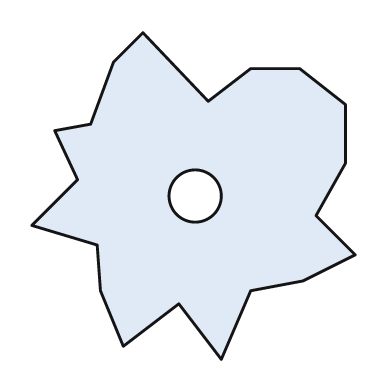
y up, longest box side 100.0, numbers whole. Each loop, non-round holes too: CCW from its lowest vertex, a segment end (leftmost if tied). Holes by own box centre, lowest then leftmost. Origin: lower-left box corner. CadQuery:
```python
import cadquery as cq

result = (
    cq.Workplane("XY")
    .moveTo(58.0, 0.0)
    .lineTo(67.0, 21.0)
    .lineTo(83.0, 24.0)
    .lineTo(99.0, 32.0)
    .lineTo(87.0, 44.0)
    .lineTo(96.0, 60.0)
    .lineTo(96.0, 78.0)
    .lineTo(82.0, 89.0)
    .lineTo(67.0, 89.0)
    .lineTo(54.0, 79.0)
    .lineTo(34.0, 100.0)
    .lineTo(25.0, 91.0)
    .lineTo(18.0, 72.0)
    .lineTo(7.0, 70.0)
    .lineTo(14.0, 55.0)
    .lineTo(0.0, 41.0)
    .lineTo(20.0, 35.0)
    .lineTo(21.0, 21.0)
    .lineTo(28.0, 4.0)
    .lineTo(45.0, 17.0)
    .close()
    .moveTo(50.0, 50.0)
    .circle(8.0)
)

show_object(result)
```